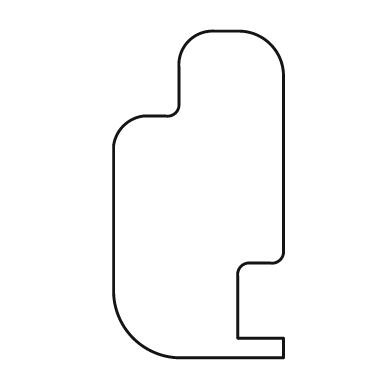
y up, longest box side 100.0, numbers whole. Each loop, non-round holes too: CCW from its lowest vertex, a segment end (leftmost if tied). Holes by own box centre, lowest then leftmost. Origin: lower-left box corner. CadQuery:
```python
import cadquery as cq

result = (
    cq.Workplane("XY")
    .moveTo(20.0, 0.0)
    .lineTo(52.0, 0.0)
    .lineTo(52.0, 6.0)
    .lineTo(38.0, 6.0)
    .lineTo(38.0, 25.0)
    .threePointArc((39.0, 28.0), (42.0, 29.0))
    .lineTo(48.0, 29.0)
    .threePointArc((51.0, 30.0), (52.0, 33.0))
    .lineTo(52.0, 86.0)
    .threePointArc((48.0, 96.0), (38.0, 100.0))
    .lineTo(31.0, 100.0)
    .threePointArc((23.0, 97.0), (20.0, 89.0))
    .lineTo(20.0, 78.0)
    .threePointArc((19.0, 75.0), (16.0, 74.0))
    .lineTo(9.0, 74.0)
    .threePointArc((3.0, 71.0), (0.0, 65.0))
    .lineTo(0.0, 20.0)
    .threePointArc((6.0, 6.0), (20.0, 0.0))
    .close()
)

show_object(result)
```